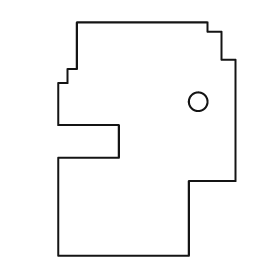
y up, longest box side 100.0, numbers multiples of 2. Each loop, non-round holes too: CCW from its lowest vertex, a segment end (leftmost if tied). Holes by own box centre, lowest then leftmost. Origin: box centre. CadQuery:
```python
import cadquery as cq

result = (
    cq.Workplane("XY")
    .moveTo(-38.0, -50.0)
    .lineTo(18.0, -50.0)
    .lineTo(18.0, -18.0)
    .lineTo(38.0, -18.0)
    .lineTo(38.0, 34.0)
    .lineTo(32.0, 34.0)
    .lineTo(32.0, 46.0)
    .lineTo(26.0, 46.0)
    .lineTo(26.0, 50.0)
    .lineTo(-30.0, 50.0)
    .lineTo(-30.0, 30.0)
    .lineTo(-34.0, 30.0)
    .lineTo(-34.0, 24.0)
    .lineTo(-38.0, 24.0)
    .lineTo(-38.0, 6.0)
    .lineTo(-12.0, 6.0)
    .lineTo(-12.0, -8.0)
    .lineTo(-38.0, -8.0)
    .close()
    .moveTo(22.0, 16.0)
    .circle(4.0)
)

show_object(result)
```